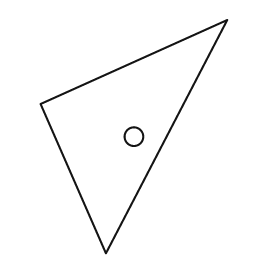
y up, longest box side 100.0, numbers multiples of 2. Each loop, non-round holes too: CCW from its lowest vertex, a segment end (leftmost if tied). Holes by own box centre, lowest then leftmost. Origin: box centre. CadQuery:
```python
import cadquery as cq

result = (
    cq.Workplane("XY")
    .moveTo(-12.0, -50.0)
    .lineTo(40.0, 50.0)
    .lineTo(-40.0, 14.0)
    .close()
    .moveTo(0.0, 0.0)
    .circle(4.0)
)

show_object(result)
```